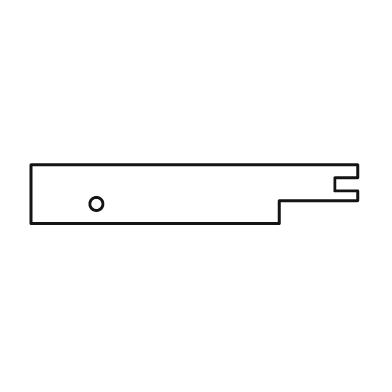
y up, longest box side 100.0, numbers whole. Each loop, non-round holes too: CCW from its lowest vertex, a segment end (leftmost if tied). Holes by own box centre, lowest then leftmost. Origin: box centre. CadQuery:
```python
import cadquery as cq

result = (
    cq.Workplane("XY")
    .moveTo(-50.0, -9.0)
    .lineTo(26.0, -9.0)
    .lineTo(26.0, -2.0)
    .lineTo(50.0, -2.0)
    .lineTo(50.0, 1.0)
    .lineTo(43.0, 1.0)
    .lineTo(43.0, 5.0)
    .lineTo(50.0, 5.0)
    .lineTo(50.0, 9.0)
    .lineTo(-50.0, 9.0)
    .close()
    .moveTo(-30.0, -3.0)
    .circle(2.0)
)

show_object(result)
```